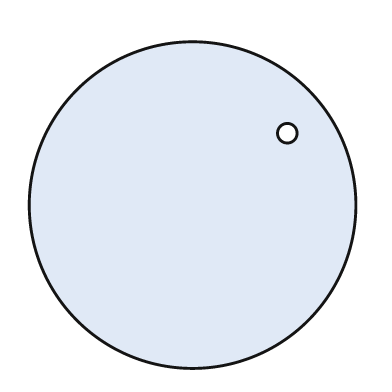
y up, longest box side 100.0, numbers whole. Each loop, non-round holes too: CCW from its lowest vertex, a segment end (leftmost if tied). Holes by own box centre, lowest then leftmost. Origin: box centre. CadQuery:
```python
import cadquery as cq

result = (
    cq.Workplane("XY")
    .moveTo(0.0, 0.0)
    .circle(50.0)
    .moveTo(29.0, 22.0)
    .circle(3.0)
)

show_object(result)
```